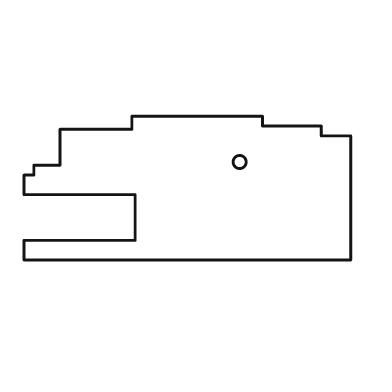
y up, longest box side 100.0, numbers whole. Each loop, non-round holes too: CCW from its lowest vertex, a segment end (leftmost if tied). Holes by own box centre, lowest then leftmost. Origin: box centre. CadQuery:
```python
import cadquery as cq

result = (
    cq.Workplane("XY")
    .moveTo(-50.0, -22.0)
    .lineTo(50.0, -22.0)
    .lineTo(50.0, 16.0)
    .lineTo(41.0, 16.0)
    .lineTo(41.0, 19.0)
    .lineTo(23.0, 19.0)
    .lineTo(23.0, 22.0)
    .lineTo(-17.0, 22.0)
    .lineTo(-17.0, 18.0)
    .lineTo(-39.0, 18.0)
    .lineTo(-39.0, 7.0)
    .lineTo(-47.0, 7.0)
    .lineTo(-47.0, 4.0)
    .lineTo(-50.0, 4.0)
    .lineTo(-50.0, -2.0)
    .lineTo(-16.0, -2.0)
    .lineTo(-16.0, -16.0)
    .lineTo(-50.0, -16.0)
    .close()
    .moveTo(16.0, 8.0)
    .circle(2.0)
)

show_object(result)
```